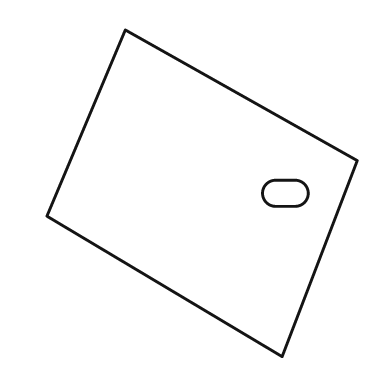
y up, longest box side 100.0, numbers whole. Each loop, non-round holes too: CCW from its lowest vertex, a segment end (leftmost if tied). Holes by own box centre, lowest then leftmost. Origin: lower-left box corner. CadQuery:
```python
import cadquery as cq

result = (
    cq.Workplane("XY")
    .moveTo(72.0, 0.0)
    .lineTo(95.0, 60.0)
    .lineTo(24.0, 100.0)
    .lineTo(0.0, 43.0)
    .close()
    .moveTo(70.0, 46.0)
    .lineTo(76.0, 46.0)
    .threePointArc((80.0, 50.0), (76.0, 54.0))
    .lineTo(70.0, 54.0)
    .threePointArc((66.0, 50.0), (70.0, 46.0))
    .close()
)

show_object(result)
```